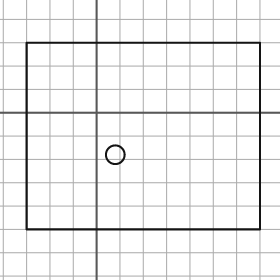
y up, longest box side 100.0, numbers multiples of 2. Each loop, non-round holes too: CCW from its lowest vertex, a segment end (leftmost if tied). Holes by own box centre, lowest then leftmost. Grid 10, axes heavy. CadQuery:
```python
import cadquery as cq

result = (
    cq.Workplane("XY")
    .moveTo(-30.0, -50.0)
    .lineTo(70.0, -50.0)
    .lineTo(70.0, 30.0)
    .lineTo(-30.0, 30.0)
    .close()
    .moveTo(8.0, -18.0)
    .circle(4.0)
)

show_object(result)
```